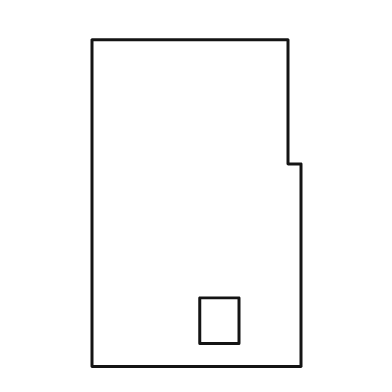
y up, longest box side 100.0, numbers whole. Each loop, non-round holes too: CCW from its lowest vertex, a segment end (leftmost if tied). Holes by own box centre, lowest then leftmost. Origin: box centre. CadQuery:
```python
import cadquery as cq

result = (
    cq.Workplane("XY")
    .moveTo(-32.0, -50.0)
    .lineTo(32.0, -50.0)
    .lineTo(32.0, 12.0)
    .lineTo(28.0, 12.0)
    .lineTo(28.0, 50.0)
    .lineTo(-32.0, 50.0)
    .close()
    .moveTo(1.0, -43.0)
    .lineTo(13.0, -43.0)
    .lineTo(13.0, -29.0)
    .lineTo(1.0, -29.0)
    .close()
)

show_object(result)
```